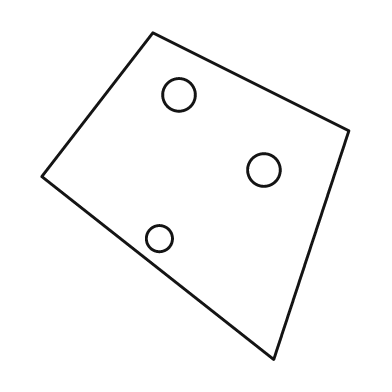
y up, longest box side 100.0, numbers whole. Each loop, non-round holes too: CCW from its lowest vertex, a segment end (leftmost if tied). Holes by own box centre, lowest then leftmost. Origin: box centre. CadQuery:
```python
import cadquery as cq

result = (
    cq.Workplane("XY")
    .moveTo(24.0, -50.0)
    .lineTo(47.0, 20.0)
    .lineTo(-13.0, 50.0)
    .lineTo(-47.0, 6.0)
    .close()
    .moveTo(-11.0, -13.0)
    .circle(4.0)
    .moveTo(21.0, 8.0)
    .circle(5.0)
    .moveTo(-5.0, 31.0)
    .circle(5.0)
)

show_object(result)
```